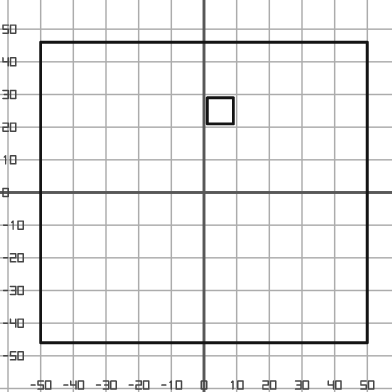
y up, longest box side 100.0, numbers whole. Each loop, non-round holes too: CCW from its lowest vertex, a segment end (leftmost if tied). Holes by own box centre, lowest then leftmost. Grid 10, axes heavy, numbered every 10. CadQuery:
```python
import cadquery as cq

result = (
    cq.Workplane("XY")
    .moveTo(-50.0, -46.0)
    .lineTo(50.0, -46.0)
    .lineTo(50.0, 46.0)
    .lineTo(-50.0, 46.0)
    .close()
    .moveTo(1.0, 21.0)
    .lineTo(9.0, 21.0)
    .lineTo(9.0, 29.0)
    .lineTo(1.0, 29.0)
    .close()
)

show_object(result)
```